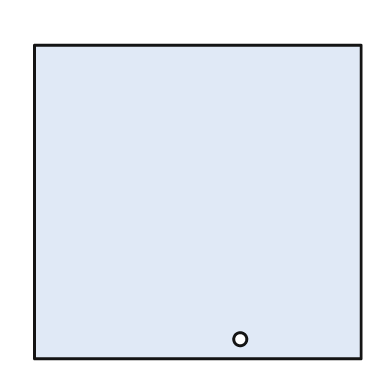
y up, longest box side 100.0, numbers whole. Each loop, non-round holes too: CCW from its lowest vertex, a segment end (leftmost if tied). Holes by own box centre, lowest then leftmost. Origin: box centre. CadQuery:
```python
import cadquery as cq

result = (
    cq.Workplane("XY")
    .moveTo(-50.0, -48.0)
    .lineTo(50.0, -48.0)
    .lineTo(50.0, 48.0)
    .lineTo(-50.0, 48.0)
    .close()
    .moveTo(13.0, -42.0)
    .circle(2.0)
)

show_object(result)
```